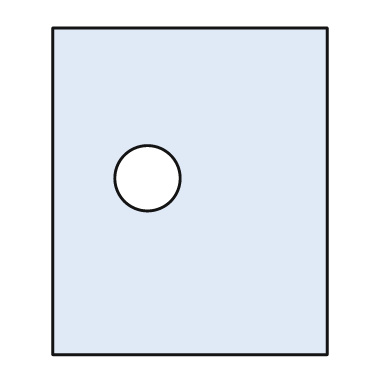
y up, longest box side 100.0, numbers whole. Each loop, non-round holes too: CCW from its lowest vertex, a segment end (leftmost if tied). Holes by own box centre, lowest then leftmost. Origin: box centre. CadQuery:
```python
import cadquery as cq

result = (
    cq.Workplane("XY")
    .moveTo(-42.0, -50.0)
    .lineTo(42.0, -50.0)
    .lineTo(42.0, 50.0)
    .lineTo(-42.0, 50.0)
    .close()
    .moveTo(-13.0, 4.0)
    .circle(10.0)
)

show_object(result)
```